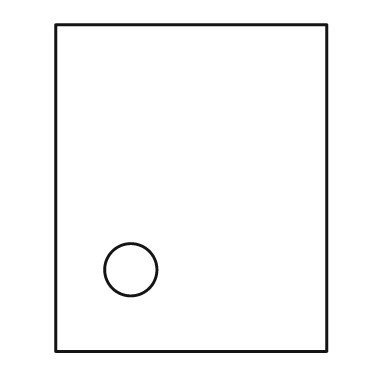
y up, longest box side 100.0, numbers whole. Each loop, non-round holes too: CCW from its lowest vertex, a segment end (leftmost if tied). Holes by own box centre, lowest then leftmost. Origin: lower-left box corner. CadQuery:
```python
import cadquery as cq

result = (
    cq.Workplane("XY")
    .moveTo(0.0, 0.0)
    .lineTo(83.0, 0.0)
    .lineTo(83.0, 100.0)
    .lineTo(0.0, 100.0)
    .close()
    .moveTo(23.0, 25.0)
    .circle(8.0)
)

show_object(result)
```